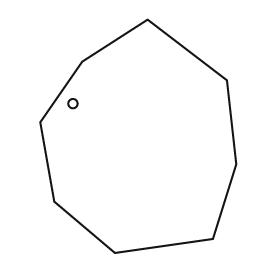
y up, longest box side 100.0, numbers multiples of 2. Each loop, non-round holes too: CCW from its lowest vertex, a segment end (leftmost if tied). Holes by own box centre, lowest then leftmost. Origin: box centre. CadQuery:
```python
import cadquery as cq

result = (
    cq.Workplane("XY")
    .moveTo(-10.0, -50.0)
    .lineTo(32.0, -44.0)
    .lineTo(42.0, -12.0)
    .lineTo(38.0, 24.0)
    .lineTo(4.0, 50.0)
    .lineTo(-24.0, 32.0)
    .lineTo(-42.0, 6.0)
    .lineTo(-36.0, -28.0)
    .close()
    .moveTo(-28.0, 14.0)
    .circle(2.0)
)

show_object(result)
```